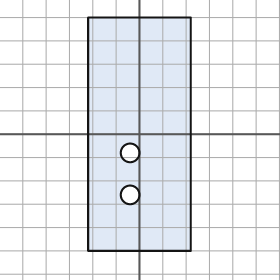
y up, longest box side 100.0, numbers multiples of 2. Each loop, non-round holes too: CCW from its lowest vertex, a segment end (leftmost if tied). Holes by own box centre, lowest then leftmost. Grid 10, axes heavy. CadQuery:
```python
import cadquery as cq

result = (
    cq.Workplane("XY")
    .moveTo(-22.0, -50.0)
    .lineTo(22.0, -50.0)
    .lineTo(22.0, 50.0)
    .lineTo(-22.0, 50.0)
    .close()
    .moveTo(-4.0, -26.0)
    .circle(4.0)
    .moveTo(-4.0, -8.0)
    .circle(4.0)
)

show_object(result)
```